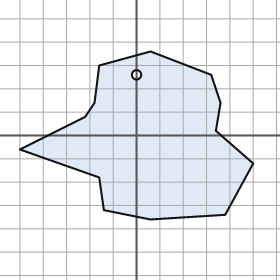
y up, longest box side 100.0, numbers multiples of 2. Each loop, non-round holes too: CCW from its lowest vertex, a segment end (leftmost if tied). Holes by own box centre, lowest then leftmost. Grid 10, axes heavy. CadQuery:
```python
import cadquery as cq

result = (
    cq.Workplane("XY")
    .moveTo(6.0, -36.0)
    .lineTo(38.0, -34.0)
    .lineTo(50.0, -12.0)
    .lineTo(34.0, 2.0)
    .lineTo(36.0, 14.0)
    .lineTo(32.0, 26.0)
    .lineTo(6.0, 36.0)
    .lineTo(-16.0, 30.0)
    .lineTo(-18.0, 14.0)
    .lineTo(-22.0, 8.0)
    .lineTo(-50.0, -6.0)
    .lineTo(-16.0, -18.0)
    .lineTo(-14.0, -32.0)
    .close()
    .moveTo(0.0, 26.0)
    .circle(2.0)
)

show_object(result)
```